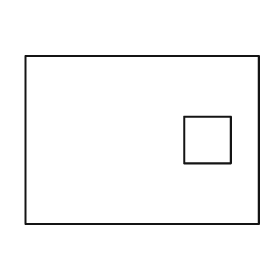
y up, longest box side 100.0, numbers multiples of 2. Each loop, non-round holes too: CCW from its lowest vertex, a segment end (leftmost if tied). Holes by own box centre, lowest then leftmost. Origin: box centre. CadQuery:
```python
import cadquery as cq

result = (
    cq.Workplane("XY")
    .moveTo(-50.0, -36.0)
    .lineTo(50.0, -36.0)
    .lineTo(50.0, 36.0)
    .lineTo(-50.0, 36.0)
    .close()
    .moveTo(18.0, -10.0)
    .lineTo(38.0, -10.0)
    .lineTo(38.0, 10.0)
    .lineTo(18.0, 10.0)
    .close()
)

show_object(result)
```